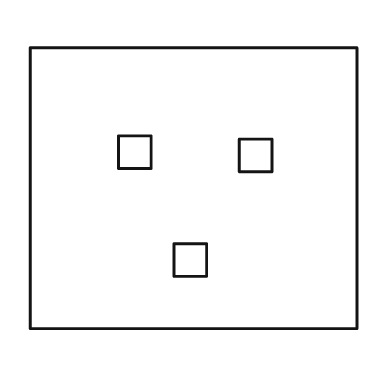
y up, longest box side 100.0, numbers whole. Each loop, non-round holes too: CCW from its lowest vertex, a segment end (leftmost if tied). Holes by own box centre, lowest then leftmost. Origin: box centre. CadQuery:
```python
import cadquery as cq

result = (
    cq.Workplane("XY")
    .moveTo(-50.0, -43.0)
    .lineTo(50.0, -43.0)
    .lineTo(50.0, 43.0)
    .lineTo(-50.0, 43.0)
    .close()
    .moveTo(-6.0, -27.0)
    .lineTo(4.0, -27.0)
    .lineTo(4.0, -17.0)
    .lineTo(-6.0, -17.0)
    .close()
    .moveTo(14.0, 5.0)
    .lineTo(24.0, 5.0)
    .lineTo(24.0, 15.0)
    .lineTo(14.0, 15.0)
    .close()
    .moveTo(-23.0, 6.0)
    .lineTo(-13.0, 6.0)
    .lineTo(-13.0, 16.0)
    .lineTo(-23.0, 16.0)
    .close()
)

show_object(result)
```